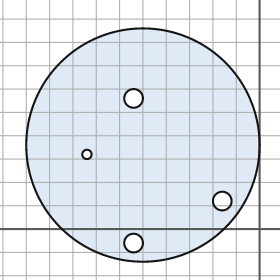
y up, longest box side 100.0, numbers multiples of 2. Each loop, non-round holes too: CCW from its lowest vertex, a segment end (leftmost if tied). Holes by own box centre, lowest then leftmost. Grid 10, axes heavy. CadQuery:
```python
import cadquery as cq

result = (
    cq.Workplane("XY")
    .moveTo(-50.0, 36.0)
    .circle(50.0)
    .moveTo(-54.0, -6.0)
    .circle(4.0)
    .moveTo(-16.0, 12.0)
    .circle(4.0)
    .moveTo(-74.0, 32.0)
    .circle(2.0)
    .moveTo(-54.0, 56.0)
    .circle(4.0)
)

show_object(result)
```